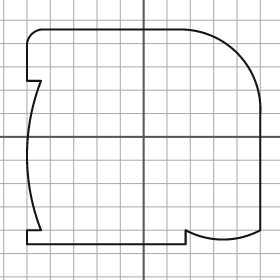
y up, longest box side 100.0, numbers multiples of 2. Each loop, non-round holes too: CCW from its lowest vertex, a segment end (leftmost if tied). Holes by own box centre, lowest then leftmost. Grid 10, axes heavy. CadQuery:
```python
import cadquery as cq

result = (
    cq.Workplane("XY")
    .moveTo(-50.0, -46.0)
    .lineTo(18.0, -46.0)
    .lineTo(18.0, -40.0)
    .threePointArc((34.0, -44.0), (50.0, -40.0))
    .lineTo(50.0, 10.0)
    .threePointArc((40.0, 36.0), (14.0, 46.0))
    .lineTo(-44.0, 46.0)
    .threePointArc((-48.0, 44.0), (-50.0, 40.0))
    .lineTo(-50.0, 24.0)
    .lineTo(-44.0, 24.0)
    .threePointArc((-50.0, -8.0), (-44.0, -40.0))
    .lineTo(-50.0, -40.0)
    .close()
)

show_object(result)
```